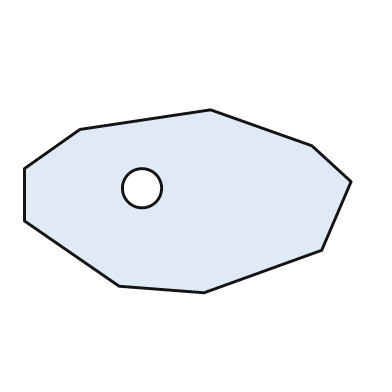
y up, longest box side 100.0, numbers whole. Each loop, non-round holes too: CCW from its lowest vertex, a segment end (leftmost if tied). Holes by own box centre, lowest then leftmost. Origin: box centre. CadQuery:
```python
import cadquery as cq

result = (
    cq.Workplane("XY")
    .moveTo(5.0, -28.0)
    .lineTo(41.0, -15.0)
    .lineTo(50.0, 6.0)
    .lineTo(38.0, 17.0)
    .lineTo(7.0, 28.0)
    .lineTo(-33.0, 22.0)
    .lineTo(-50.0, 10.0)
    .lineTo(-50.0, -6.0)
    .lineTo(-21.0, -26.0)
    .close()
    .moveTo(-14.0, 4.0)
    .circle(6.0)
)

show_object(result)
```